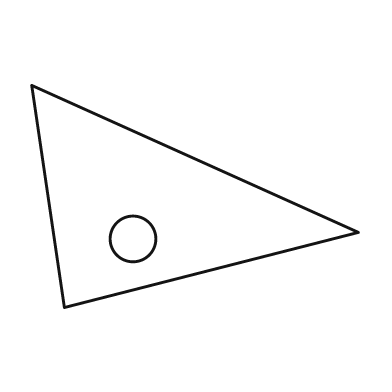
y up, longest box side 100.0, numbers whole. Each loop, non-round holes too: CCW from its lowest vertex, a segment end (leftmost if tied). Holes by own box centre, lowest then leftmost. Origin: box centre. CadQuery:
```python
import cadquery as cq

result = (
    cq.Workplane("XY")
    .moveTo(-40.0, -34.0)
    .lineTo(50.0, -11.0)
    .lineTo(-50.0, 34.0)
    .close()
    .moveTo(-19.0, -13.0)
    .circle(7.0)
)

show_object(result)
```